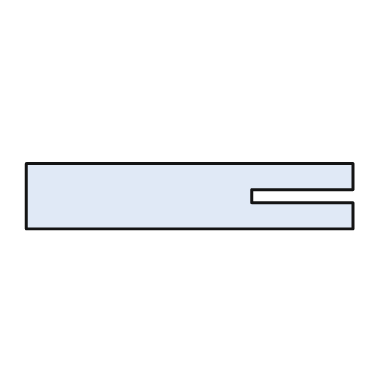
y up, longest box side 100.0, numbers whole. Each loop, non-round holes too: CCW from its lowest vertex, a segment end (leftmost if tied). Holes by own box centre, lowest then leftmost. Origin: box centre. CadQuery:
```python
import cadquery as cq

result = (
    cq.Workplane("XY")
    .moveTo(-50.0, -10.0)
    .lineTo(50.0, -10.0)
    .lineTo(50.0, -2.0)
    .lineTo(19.0, -2.0)
    .lineTo(19.0, 2.0)
    .lineTo(50.0, 2.0)
    .lineTo(50.0, 10.0)
    .lineTo(-50.0, 10.0)
    .close()
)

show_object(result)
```